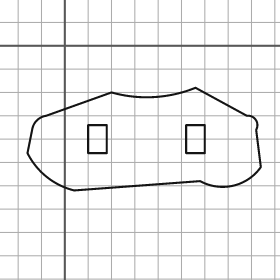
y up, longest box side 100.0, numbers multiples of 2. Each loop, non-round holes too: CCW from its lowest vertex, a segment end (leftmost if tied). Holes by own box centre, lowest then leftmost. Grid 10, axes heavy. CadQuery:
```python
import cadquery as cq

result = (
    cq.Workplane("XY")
    .moveTo(4.0, -62.0)
    .lineTo(58.0, -58.0)
    .threePointArc((72.0, -60.0), (84.0, -52.0))
    .lineTo(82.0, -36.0)
    .threePointArc((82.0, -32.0), (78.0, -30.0))
    .lineTo(56.0, -18.0)
    .threePointArc((38.0, -22.0), (20.0, -20.0))
    .lineTo(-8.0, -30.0)
    .threePointArc((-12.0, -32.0), (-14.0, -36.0))
    .lineTo(-16.0, -46.0)
    .threePointArc((-8.0, -56.0), (4.0, -62.0))
    .close()
    .moveTo(10.0, -46.0)
    .lineTo(18.0, -46.0)
    .lineTo(18.0, -34.0)
    .lineTo(10.0, -34.0)
    .close()
    .moveTo(52.0, -46.0)
    .lineTo(60.0, -46.0)
    .lineTo(60.0, -34.0)
    .lineTo(52.0, -34.0)
    .close()
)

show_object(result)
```